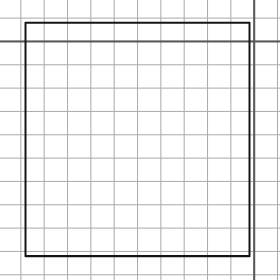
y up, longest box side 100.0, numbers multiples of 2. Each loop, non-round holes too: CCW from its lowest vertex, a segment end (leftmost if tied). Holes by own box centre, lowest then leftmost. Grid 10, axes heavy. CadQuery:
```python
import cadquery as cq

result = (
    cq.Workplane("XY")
    .moveTo(-98.0, -92.0)
    .lineTo(-2.0, -92.0)
    .lineTo(-2.0, 8.0)
    .lineTo(-98.0, 8.0)
    .close()
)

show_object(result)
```